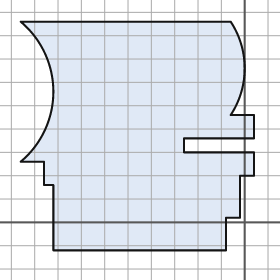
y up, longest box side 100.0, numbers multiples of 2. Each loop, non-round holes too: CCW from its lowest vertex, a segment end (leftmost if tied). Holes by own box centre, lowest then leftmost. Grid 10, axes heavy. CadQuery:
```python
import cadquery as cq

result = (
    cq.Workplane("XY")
    .moveTo(-82.0, -12.0)
    .lineTo(-8.0, -12.0)
    .lineTo(-8.0, 2.0)
    .lineTo(-2.0, 2.0)
    .lineTo(-2.0, 20.0)
    .lineTo(4.0, 20.0)
    .lineTo(4.0, 30.0)
    .lineTo(-26.0, 30.0)
    .lineTo(-26.0, 36.0)
    .lineTo(4.0, 36.0)
    .lineTo(4.0, 46.0)
    .lineTo(-6.0, 46.0)
    .threePointArc((0.0, 66.0), (-6.0, 86.0))
    .lineTo(-96.0, 86.0)
    .threePointArc((-82.0, 56.0), (-96.0, 26.0))
    .lineTo(-86.0, 26.0)
    .lineTo(-86.0, 16.0)
    .lineTo(-82.0, 16.0)
    .close()
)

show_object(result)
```